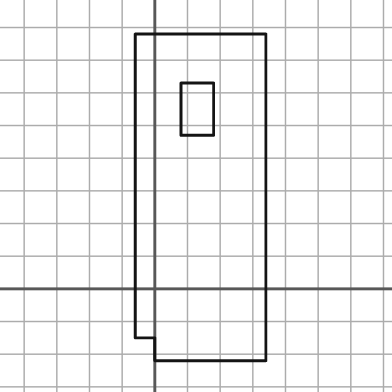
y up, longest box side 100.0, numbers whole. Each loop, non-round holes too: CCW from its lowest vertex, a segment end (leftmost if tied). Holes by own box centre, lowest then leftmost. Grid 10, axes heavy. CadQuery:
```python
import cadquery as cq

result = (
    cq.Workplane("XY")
    .moveTo(0.0, -22.0)
    .lineTo(34.0, -22.0)
    .lineTo(34.0, 78.0)
    .lineTo(-6.0, 78.0)
    .lineTo(-6.0, -15.0)
    .lineTo(0.0, -15.0)
    .close()
    .moveTo(8.0, 47.0)
    .lineTo(18.0, 47.0)
    .lineTo(18.0, 63.0)
    .lineTo(8.0, 63.0)
    .close()
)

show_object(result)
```